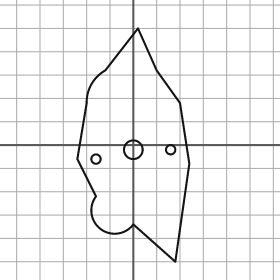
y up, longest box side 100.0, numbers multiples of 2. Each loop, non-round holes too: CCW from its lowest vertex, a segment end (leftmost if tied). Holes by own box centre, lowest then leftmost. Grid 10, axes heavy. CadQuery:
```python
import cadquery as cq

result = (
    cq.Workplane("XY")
    .moveTo(18.0, -50.0)
    .lineTo(24.0, -8.0)
    .lineTo(20.0, 18.0)
    .lineTo(10.0, 32.0)
    .lineTo(2.0, 50.0)
    .lineTo(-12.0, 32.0)
    .threePointArc((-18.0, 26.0), (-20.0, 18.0))
    .lineTo(-24.0, -6.0)
    .lineTo(-16.0, -22.0)
    .threePointArc((-14.0, -36.0), (0.0, -34.0))
    .close()
    .moveTo(-16.0, -6.0)
    .circle(2.0)
    .moveTo(0.0, -2.0)
    .circle(4.0)
    .moveTo(16.0, -2.0)
    .circle(2.0)
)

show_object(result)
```